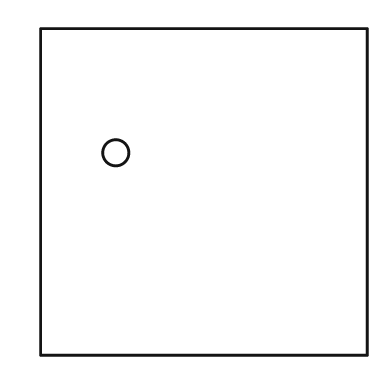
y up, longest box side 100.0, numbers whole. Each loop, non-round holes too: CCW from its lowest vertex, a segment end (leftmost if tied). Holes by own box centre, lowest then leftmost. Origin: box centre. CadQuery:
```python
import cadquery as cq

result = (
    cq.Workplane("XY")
    .moveTo(-50.0, -50.0)
    .lineTo(50.0, -50.0)
    .lineTo(50.0, 50.0)
    .lineTo(-50.0, 50.0)
    .close()
    .moveTo(-27.0, 12.0)
    .circle(4.0)
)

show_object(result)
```